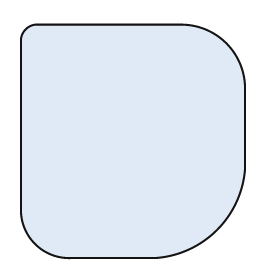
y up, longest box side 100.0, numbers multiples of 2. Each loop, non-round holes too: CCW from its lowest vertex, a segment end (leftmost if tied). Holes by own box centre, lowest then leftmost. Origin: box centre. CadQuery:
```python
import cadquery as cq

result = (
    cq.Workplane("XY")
    .moveTo(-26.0, -50.0)
    .lineTo(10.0, -50.0)
    .threePointArc((36.0, -38.0), (48.0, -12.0))
    .lineTo(48.0, 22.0)
    .threePointArc((40.0, 42.0), (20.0, 50.0))
    .lineTo(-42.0, 50.0)
    .threePointArc((-46.0, 48.0), (-48.0, 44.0))
    .lineTo(-48.0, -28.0)
    .threePointArc((-42.0, -44.0), (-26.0, -50.0))
    .close()
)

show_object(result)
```